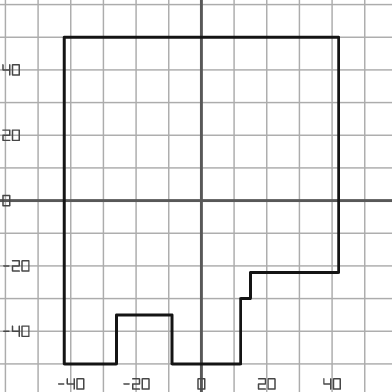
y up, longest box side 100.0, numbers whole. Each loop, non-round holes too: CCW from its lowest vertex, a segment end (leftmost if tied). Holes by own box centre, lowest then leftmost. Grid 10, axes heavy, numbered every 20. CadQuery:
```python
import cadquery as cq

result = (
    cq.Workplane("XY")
    .moveTo(-42.0, -50.0)
    .lineTo(-26.0, -50.0)
    .lineTo(-26.0, -35.0)
    .lineTo(-9.0, -35.0)
    .lineTo(-9.0, -50.0)
    .lineTo(12.0, -50.0)
    .lineTo(12.0, -30.0)
    .lineTo(15.0, -30.0)
    .lineTo(15.0, -22.0)
    .lineTo(42.0, -22.0)
    .lineTo(42.0, 50.0)
    .lineTo(-42.0, 50.0)
    .close()
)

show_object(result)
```